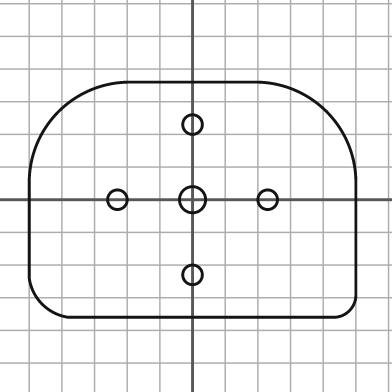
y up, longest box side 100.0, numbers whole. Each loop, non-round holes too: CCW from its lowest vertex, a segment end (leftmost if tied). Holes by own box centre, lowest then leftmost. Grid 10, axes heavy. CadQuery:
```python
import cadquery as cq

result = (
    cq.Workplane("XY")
    .moveTo(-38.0, -36.0)
    .lineTo(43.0, -36.0)
    .threePointArc((48.0, -34.0), (50.0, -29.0))
    .lineTo(50.0, 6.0)
    .threePointArc((41.0, 27.0), (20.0, 36.0))
    .lineTo(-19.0, 36.0)
    .threePointArc((-41.0, 27.0), (-50.0, 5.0))
    .lineTo(-50.0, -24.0)
    .threePointArc((-46.0, -32.0), (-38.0, -36.0))
    .close()
    .moveTo(0.0, -23.0)
    .circle(3.0)
    .moveTo(-23.0, 0.0)
    .circle(3.0)
    .moveTo(0.0, 0.0)
    .circle(4.0)
    .moveTo(23.0, 0.0)
    .circle(3.0)
    .moveTo(0.0, 23.0)
    .circle(3.0)
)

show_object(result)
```